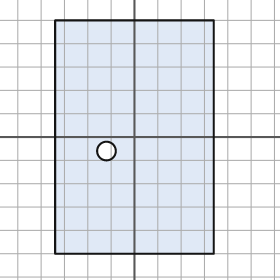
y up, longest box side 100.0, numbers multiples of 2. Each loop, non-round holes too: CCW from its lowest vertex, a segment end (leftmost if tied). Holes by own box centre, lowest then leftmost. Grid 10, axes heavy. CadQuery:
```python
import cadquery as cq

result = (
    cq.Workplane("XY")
    .moveTo(-34.0, -50.0)
    .lineTo(34.0, -50.0)
    .lineTo(34.0, 50.0)
    .lineTo(-34.0, 50.0)
    .close()
    .moveTo(-12.0, -6.0)
    .circle(4.0)
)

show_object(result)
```